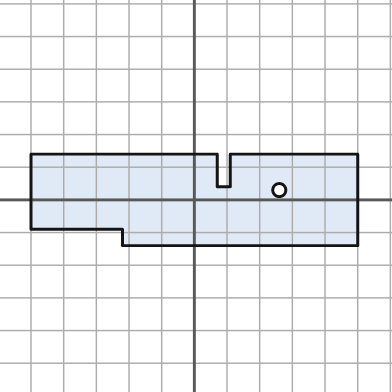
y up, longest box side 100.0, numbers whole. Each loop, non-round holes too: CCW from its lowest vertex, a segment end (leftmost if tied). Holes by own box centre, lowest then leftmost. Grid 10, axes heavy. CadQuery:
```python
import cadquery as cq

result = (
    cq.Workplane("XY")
    .moveTo(-22.0, -14.0)
    .lineTo(50.0, -14.0)
    .lineTo(50.0, 14.0)
    .lineTo(11.0, 14.0)
    .lineTo(11.0, 4.0)
    .lineTo(7.0, 4.0)
    .lineTo(7.0, 14.0)
    .lineTo(-50.0, 14.0)
    .lineTo(-50.0, -9.0)
    .lineTo(-22.0, -9.0)
    .close()
    .moveTo(26.0, 3.0)
    .circle(2.0)
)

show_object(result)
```